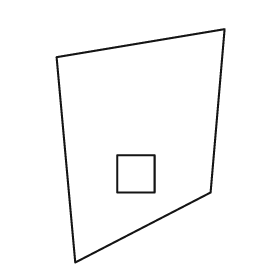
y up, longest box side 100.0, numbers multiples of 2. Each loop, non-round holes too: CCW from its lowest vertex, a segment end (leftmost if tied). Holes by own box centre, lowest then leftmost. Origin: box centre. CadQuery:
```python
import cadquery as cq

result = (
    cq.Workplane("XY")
    .moveTo(-28.0, -50.0)
    .lineTo(30.0, -20.0)
    .lineTo(36.0, 50.0)
    .lineTo(-36.0, 38.0)
    .close()
    .moveTo(-10.0, -20.0)
    .lineTo(6.0, -20.0)
    .lineTo(6.0, -4.0)
    .lineTo(-10.0, -4.0)
    .close()
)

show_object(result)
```